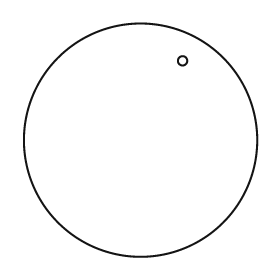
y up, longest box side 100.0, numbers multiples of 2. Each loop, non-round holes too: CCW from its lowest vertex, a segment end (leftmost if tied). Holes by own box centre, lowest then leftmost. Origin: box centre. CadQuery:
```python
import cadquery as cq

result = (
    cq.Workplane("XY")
    .moveTo(0.0, 0.0)
    .circle(50.0)
    .moveTo(18.0, 34.0)
    .circle(2.0)
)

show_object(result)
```